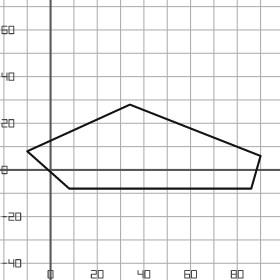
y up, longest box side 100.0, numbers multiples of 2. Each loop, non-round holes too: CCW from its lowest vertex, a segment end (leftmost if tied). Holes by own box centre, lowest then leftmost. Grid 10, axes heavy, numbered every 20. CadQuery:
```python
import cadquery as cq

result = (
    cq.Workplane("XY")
    .moveTo(8.0, -8.0)
    .lineTo(86.0, -8.0)
    .lineTo(90.0, 6.0)
    .lineTo(34.0, 28.0)
    .lineTo(-10.0, 8.0)
    .close()
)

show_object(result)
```